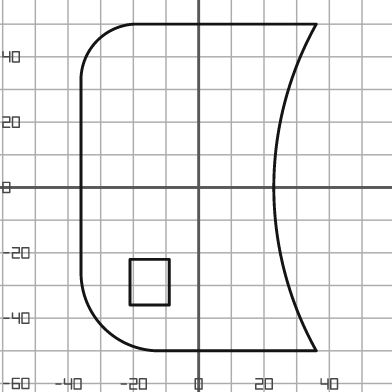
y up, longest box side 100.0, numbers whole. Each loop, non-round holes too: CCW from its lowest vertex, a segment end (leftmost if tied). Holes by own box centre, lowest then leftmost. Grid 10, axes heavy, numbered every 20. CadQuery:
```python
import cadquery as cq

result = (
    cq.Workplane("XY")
    .moveTo(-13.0, -50.0)
    .lineTo(36.0, -50.0)
    .threePointArc((23.0, 0.0), (36.0, 50.0))
    .lineTo(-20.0, 50.0)
    .threePointArc((-31.0, 45.0), (-36.0, 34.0))
    .lineTo(-36.0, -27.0)
    .threePointArc((-29.0, -43.0), (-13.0, -50.0))
    .close()
    .moveTo(-21.0, -36.0)
    .lineTo(-9.0, -36.0)
    .lineTo(-9.0, -22.0)
    .lineTo(-21.0, -22.0)
    .close()
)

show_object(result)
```